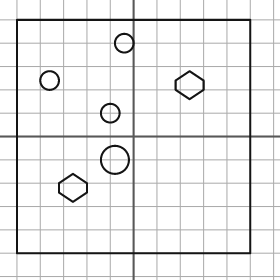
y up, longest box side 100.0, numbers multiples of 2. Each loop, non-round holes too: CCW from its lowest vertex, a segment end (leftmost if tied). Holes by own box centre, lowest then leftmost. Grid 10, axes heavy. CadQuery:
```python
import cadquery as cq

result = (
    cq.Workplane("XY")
    .moveTo(-50.0, -50.0)
    .lineTo(50.0, -50.0)
    .lineTo(50.0, 50.0)
    .lineTo(-50.0, 50.0)
    .close()
    .moveTo(-26.0, -28.0)
    .lineTo(-20.0, -24.0)
    .lineTo(-20.0, -20.0)
    .lineTo(-26.0, -16.0)
    .lineTo(-32.0, -20.0)
    .lineTo(-32.0, -24.0)
    .close()
    .moveTo(-8.0, -10.0)
    .circle(6.0)
    .moveTo(-10.0, 10.0)
    .circle(4.0)
    .moveTo(24.0, 16.0)
    .lineTo(30.0, 20.0)
    .lineTo(30.0, 24.0)
    .lineTo(24.0, 28.0)
    .lineTo(18.0, 24.0)
    .lineTo(18.0, 20.0)
    .close()
    .moveTo(-36.0, 24.0)
    .circle(4.0)
    .moveTo(-4.0, 40.0)
    .circle(4.0)
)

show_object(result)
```